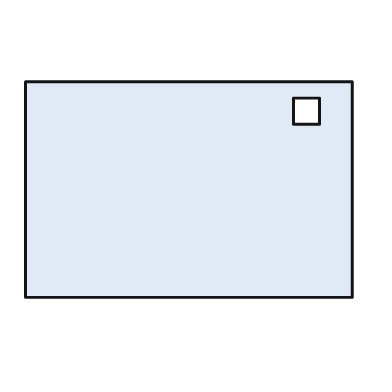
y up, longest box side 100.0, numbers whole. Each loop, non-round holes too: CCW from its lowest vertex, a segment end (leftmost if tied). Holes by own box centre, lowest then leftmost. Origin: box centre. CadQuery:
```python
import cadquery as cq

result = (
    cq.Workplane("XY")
    .moveTo(-50.0, -33.0)
    .lineTo(50.0, -33.0)
    .lineTo(50.0, 33.0)
    .lineTo(-50.0, 33.0)
    .close()
    .moveTo(32.0, 20.0)
    .lineTo(40.0, 20.0)
    .lineTo(40.0, 28.0)
    .lineTo(32.0, 28.0)
    .close()
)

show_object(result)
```